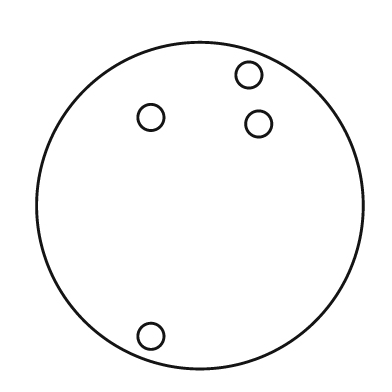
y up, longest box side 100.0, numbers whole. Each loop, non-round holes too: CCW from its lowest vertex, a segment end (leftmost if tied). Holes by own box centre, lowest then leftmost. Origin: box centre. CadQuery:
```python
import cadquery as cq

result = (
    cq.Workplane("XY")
    .moveTo(0.0, 0.0)
    .circle(50.0)
    .moveTo(-15.0, -40.0)
    .circle(4.0)
    .moveTo(18.0, 25.0)
    .circle(4.0)
    .moveTo(-15.0, 27.0)
    .circle(4.0)
    .moveTo(15.0, 40.0)
    .circle(4.0)
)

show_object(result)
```